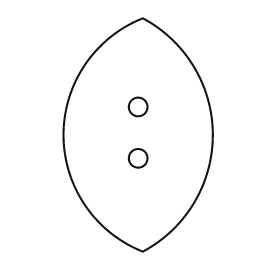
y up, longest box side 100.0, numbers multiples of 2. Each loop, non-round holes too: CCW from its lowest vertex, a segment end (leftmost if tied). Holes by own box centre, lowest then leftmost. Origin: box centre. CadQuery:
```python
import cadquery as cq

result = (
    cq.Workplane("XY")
    .moveTo(2.0, -50.0)
    .threePointArc((32.0, 0.0), (2.0, 50.0))
    .threePointArc((-32.0, 0.0), (2.0, -50.0))
    .close()
    .moveTo(0.0, -10.0)
    .circle(4.0)
    .moveTo(0.0, 12.0)
    .circle(4.0)
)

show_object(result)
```